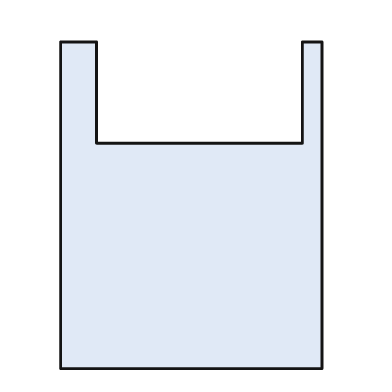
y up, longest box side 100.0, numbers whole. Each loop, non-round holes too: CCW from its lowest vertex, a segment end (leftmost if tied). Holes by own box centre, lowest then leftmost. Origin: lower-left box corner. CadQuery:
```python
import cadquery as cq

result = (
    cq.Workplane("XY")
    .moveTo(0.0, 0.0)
    .lineTo(80.0, 0.0)
    .lineTo(80.0, 100.0)
    .lineTo(74.0, 100.0)
    .lineTo(74.0, 69.0)
    .lineTo(11.0, 69.0)
    .lineTo(11.0, 100.0)
    .lineTo(0.0, 100.0)
    .close()
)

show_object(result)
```